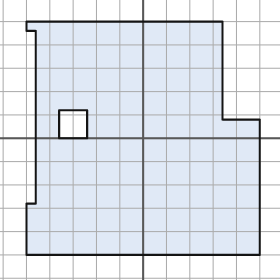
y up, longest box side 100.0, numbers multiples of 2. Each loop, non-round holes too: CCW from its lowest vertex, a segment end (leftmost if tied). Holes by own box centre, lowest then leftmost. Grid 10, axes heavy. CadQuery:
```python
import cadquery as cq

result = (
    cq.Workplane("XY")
    .moveTo(-50.0, -50.0)
    .lineTo(50.0, -50.0)
    .lineTo(50.0, 8.0)
    .lineTo(34.0, 8.0)
    .lineTo(34.0, 50.0)
    .lineTo(-50.0, 50.0)
    .lineTo(-50.0, 46.0)
    .lineTo(-46.0, 46.0)
    .lineTo(-46.0, -28.0)
    .lineTo(-50.0, -28.0)
    .close()
    .moveTo(-36.0, 0.0)
    .lineTo(-24.0, 0.0)
    .lineTo(-24.0, 12.0)
    .lineTo(-36.0, 12.0)
    .close()
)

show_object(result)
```